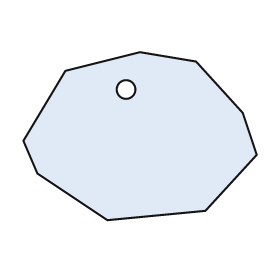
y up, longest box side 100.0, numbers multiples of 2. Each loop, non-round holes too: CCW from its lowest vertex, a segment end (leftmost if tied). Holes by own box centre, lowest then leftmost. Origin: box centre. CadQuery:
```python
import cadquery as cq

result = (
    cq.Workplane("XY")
    .moveTo(-14.0, -36.0)
    .lineTo(28.0, -32.0)
    .lineTo(50.0, -8.0)
    .lineTo(44.0, 10.0)
    .lineTo(24.0, 32.0)
    .lineTo(0.0, 36.0)
    .lineTo(-32.0, 28.0)
    .lineTo(-50.0, -2.0)
    .lineTo(-44.0, -16.0)
    .close()
    .moveTo(-6.0, 20.0)
    .circle(4.0)
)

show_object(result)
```